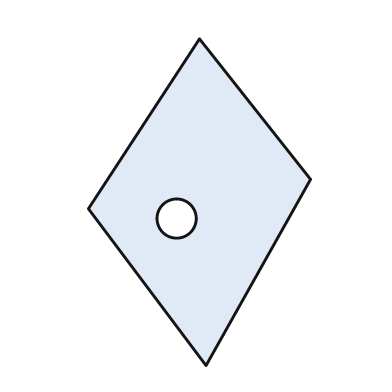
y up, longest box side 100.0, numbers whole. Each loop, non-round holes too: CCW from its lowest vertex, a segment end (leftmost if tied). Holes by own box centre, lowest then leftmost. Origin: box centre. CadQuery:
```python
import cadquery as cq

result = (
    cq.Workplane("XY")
    .moveTo(2.0, -50.0)
    .lineTo(34.0, 7.0)
    .lineTo(0.0, 50.0)
    .lineTo(-34.0, -2.0)
    .close()
    .moveTo(-7.0, -5.0)
    .circle(6.0)
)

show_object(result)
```